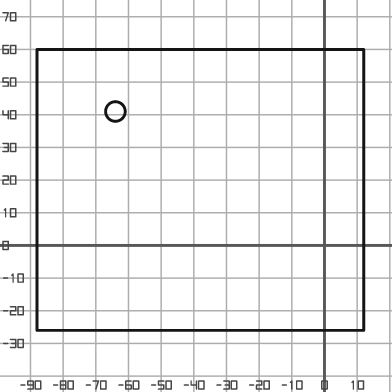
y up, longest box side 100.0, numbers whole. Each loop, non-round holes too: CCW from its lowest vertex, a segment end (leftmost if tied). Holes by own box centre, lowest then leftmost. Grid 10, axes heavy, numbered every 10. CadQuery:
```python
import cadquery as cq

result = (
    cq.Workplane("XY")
    .moveTo(-88.0, -26.0)
    .lineTo(12.0, -26.0)
    .lineTo(12.0, 60.0)
    .lineTo(-88.0, 60.0)
    .close()
    .moveTo(-64.0, 41.0)
    .circle(3.0)
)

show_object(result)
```